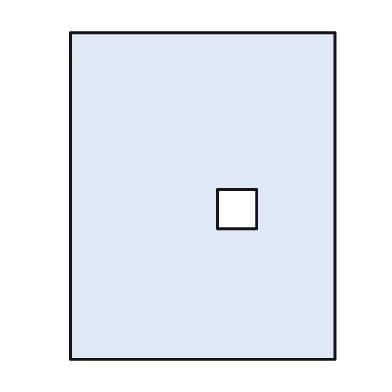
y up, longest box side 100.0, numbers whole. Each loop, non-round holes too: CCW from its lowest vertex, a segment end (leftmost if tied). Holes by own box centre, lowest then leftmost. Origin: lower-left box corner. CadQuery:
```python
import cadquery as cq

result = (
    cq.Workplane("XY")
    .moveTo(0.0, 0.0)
    .lineTo(81.0, 0.0)
    .lineTo(81.0, 100.0)
    .lineTo(0.0, 100.0)
    .close()
    .moveTo(45.0, 40.0)
    .lineTo(57.0, 40.0)
    .lineTo(57.0, 52.0)
    .lineTo(45.0, 52.0)
    .close()
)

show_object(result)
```